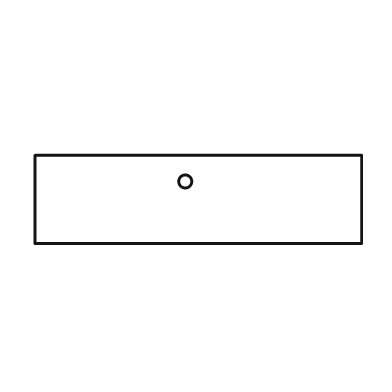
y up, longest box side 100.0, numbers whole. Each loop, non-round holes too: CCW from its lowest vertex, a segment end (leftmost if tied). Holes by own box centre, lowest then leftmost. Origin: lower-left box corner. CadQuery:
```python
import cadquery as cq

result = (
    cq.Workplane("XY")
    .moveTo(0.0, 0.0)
    .lineTo(100.0, 0.0)
    .lineTo(100.0, 27.0)
    .lineTo(0.0, 27.0)
    .close()
    .moveTo(46.0, 19.0)
    .circle(2.0)
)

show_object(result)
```